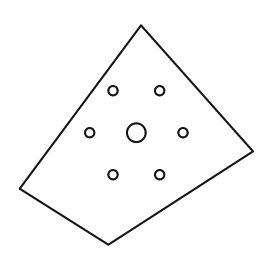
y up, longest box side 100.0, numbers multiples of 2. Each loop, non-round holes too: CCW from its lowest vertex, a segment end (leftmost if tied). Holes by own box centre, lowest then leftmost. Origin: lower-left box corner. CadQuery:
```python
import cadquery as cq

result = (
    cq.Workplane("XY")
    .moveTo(38.0, 0.0)
    .lineTo(100.0, 40.0)
    .lineTo(52.0, 94.0)
    .lineTo(0.0, 24.0)
    .close()
    .moveTo(40.0, 30.0)
    .circle(2.0)
    .moveTo(60.0, 30.0)
    .circle(2.0)
    .moveTo(30.0, 48.0)
    .circle(2.0)
    .moveTo(50.0, 48.0)
    .circle(4.0)
    .moveTo(70.0, 48.0)
    .circle(2.0)
    .moveTo(40.0, 66.0)
    .circle(2.0)
    .moveTo(60.0, 66.0)
    .circle(2.0)
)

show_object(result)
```